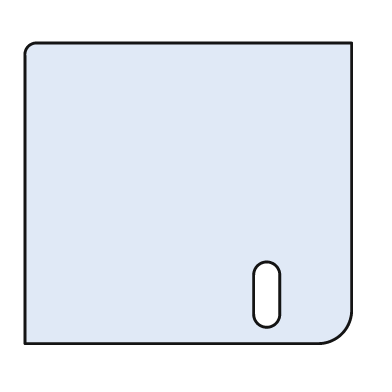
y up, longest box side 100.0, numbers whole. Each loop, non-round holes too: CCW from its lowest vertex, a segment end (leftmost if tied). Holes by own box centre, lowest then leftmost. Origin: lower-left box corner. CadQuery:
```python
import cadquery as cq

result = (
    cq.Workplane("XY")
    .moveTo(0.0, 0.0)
    .lineTo(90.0, 0.0)
    .threePointArc((97.0, 3.0), (100.0, 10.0))
    .lineTo(100.0, 92.0)
    .lineTo(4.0, 92.0)
    .threePointArc((1.0, 91.0), (0.0, 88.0))
    .close()
    .moveTo(70.0, 9.0)
    .threePointArc((74.0, 5.0), (78.0, 9.0))
    .lineTo(78.0, 21.0)
    .threePointArc((74.0, 25.0), (70.0, 21.0))
    .close()
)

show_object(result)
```